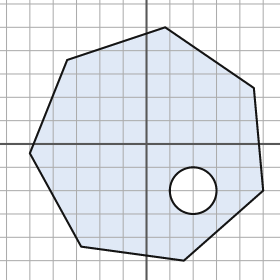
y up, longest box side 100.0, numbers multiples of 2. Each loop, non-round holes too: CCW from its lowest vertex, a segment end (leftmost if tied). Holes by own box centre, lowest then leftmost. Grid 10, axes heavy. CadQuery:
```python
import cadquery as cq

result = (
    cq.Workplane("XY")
    .moveTo(16.0, -50.0)
    .lineTo(50.0, -20.0)
    .lineTo(46.0, 24.0)
    .lineTo(8.0, 50.0)
    .lineTo(-34.0, 36.0)
    .lineTo(-50.0, -4.0)
    .lineTo(-28.0, -44.0)
    .close()
    .moveTo(20.0, -20.0)
    .circle(10.0)
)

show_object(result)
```